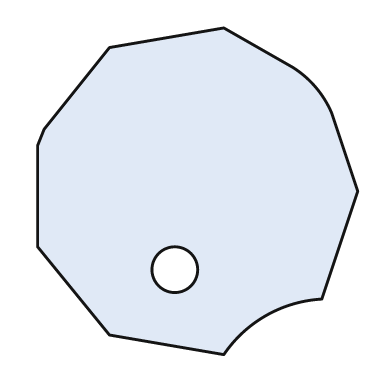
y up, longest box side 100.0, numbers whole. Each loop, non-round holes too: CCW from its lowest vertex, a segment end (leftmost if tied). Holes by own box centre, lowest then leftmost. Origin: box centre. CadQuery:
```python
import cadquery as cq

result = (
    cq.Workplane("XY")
    .moveTo(8.0, -50.0)
    .threePointArc((21.0, -38.0), (38.0, -33.0))
    .lineTo(49.0, 0.0)
    .lineTo(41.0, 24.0)
    .threePointArc((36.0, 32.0), (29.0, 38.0))
    .lineTo(8.0, 50.0)
    .lineTo(-27.0, 44.0)
    .lineTo(-47.0, 19.0)
    .lineTo(-49.0, 14.0)
    .lineTo(-49.0, -17.0)
    .lineTo(-27.0, -44.0)
    .close()
    .moveTo(-7.0, -24.0)
    .circle(7.0)
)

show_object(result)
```